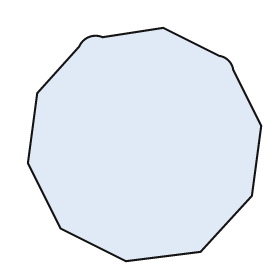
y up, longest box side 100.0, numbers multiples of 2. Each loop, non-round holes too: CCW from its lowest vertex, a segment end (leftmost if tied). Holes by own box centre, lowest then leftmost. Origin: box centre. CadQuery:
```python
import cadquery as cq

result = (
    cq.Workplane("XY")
    .moveTo(-8.0, -50.0)
    .lineTo(24.0, -46.0)
    .lineTo(46.0, -22.0)
    .lineTo(50.0, 8.0)
    .lineTo(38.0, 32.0)
    .threePointArc((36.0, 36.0), (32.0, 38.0))
    .lineTo(8.0, 50.0)
    .lineTo(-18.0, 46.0)
    .threePointArc((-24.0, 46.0), (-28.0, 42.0))
    .lineTo(-46.0, 22.0)
    .lineTo(-50.0, -8.0)
    .lineTo(-36.0, -36.0)
    .close()
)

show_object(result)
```